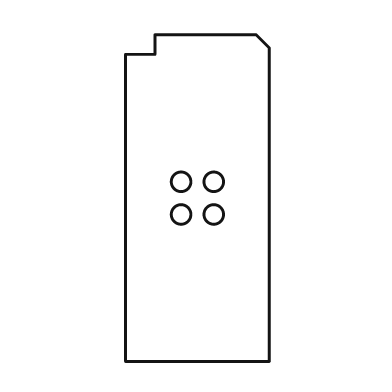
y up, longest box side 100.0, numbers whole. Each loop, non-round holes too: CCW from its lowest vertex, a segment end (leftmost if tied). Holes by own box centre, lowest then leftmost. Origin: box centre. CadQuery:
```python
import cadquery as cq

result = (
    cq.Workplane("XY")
    .moveTo(-22.0, -50.0)
    .lineTo(22.0, -50.0)
    .lineTo(22.0, 46.0)
    .lineTo(18.0, 50.0)
    .lineTo(-13.0, 50.0)
    .lineTo(-13.0, 44.0)
    .lineTo(-22.0, 44.0)
    .close()
    .moveTo(-5.0, -5.0)
    .circle(3.0)
    .moveTo(5.0, -5.0)
    .circle(3.0)
    .moveTo(-5.0, 5.0)
    .circle(3.0)
    .moveTo(5.0, 5.0)
    .circle(3.0)
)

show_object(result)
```